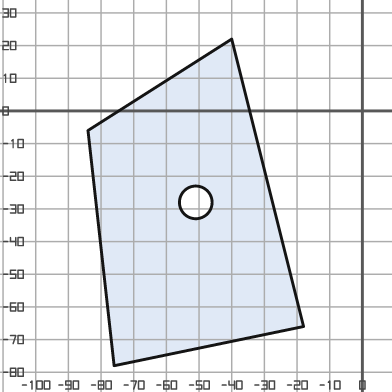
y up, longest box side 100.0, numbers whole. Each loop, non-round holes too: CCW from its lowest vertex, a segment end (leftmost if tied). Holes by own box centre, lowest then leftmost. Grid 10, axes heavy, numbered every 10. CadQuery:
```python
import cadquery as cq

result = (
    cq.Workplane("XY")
    .moveTo(-76.0, -78.0)
    .lineTo(-18.0, -66.0)
    .lineTo(-40.0, 22.0)
    .lineTo(-84.0, -6.0)
    .close()
    .moveTo(-51.0, -28.0)
    .circle(5.0)
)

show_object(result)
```